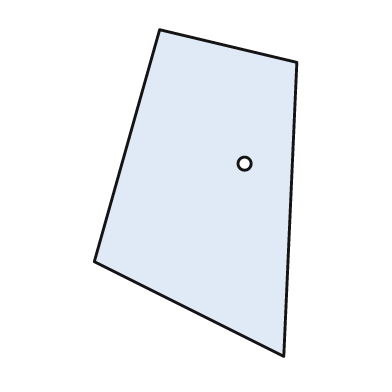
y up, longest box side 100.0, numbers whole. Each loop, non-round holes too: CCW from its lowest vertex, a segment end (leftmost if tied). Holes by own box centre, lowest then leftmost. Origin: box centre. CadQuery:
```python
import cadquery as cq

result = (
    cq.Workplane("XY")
    .moveTo(27.0, -50.0)
    .lineTo(31.0, 40.0)
    .lineTo(-11.0, 50.0)
    .lineTo(-31.0, -21.0)
    .close()
    .moveTo(15.0, 9.0)
    .circle(2.0)
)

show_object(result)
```